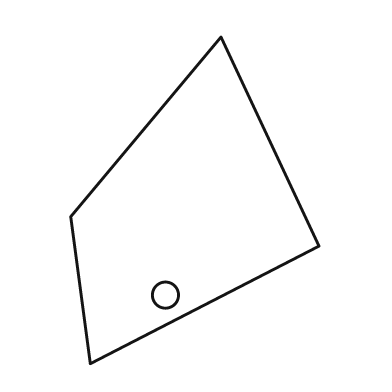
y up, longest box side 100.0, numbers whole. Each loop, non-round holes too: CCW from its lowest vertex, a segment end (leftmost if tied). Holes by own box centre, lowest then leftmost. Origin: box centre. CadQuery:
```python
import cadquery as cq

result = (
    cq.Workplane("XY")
    .moveTo(-32.0, -50.0)
    .lineTo(38.0, -14.0)
    .lineTo(8.0, 50.0)
    .lineTo(-38.0, -5.0)
    .close()
    .moveTo(-9.0, -29.0)
    .circle(4.0)
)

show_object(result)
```